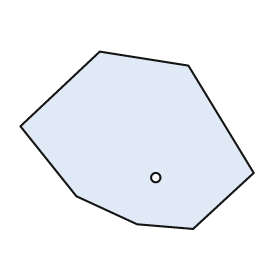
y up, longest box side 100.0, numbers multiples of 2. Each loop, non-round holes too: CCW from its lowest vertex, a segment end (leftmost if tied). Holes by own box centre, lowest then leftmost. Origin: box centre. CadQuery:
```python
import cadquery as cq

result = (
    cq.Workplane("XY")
    .moveTo(24.0, -38.0)
    .lineTo(50.0, -14.0)
    .lineTo(22.0, 32.0)
    .lineTo(-16.0, 38.0)
    .lineTo(-50.0, 6.0)
    .lineTo(-26.0, -24.0)
    .lineTo(0.0, -36.0)
    .close()
    .moveTo(8.0, -16.0)
    .circle(2.0)
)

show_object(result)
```